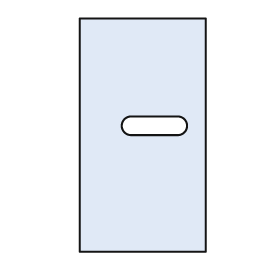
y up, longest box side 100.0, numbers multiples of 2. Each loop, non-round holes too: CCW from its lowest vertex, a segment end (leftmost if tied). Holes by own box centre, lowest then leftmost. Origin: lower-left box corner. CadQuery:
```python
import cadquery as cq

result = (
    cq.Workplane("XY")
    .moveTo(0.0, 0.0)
    .lineTo(54.0, 0.0)
    .lineTo(54.0, 100.0)
    .lineTo(0.0, 100.0)
    .close()
    .moveTo(22.0, 50.0)
    .lineTo(42.0, 50.0)
    .threePointArc((46.0, 54.0), (42.0, 58.0))
    .lineTo(22.0, 58.0)
    .threePointArc((18.0, 54.0), (22.0, 50.0))
    .close()
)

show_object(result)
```